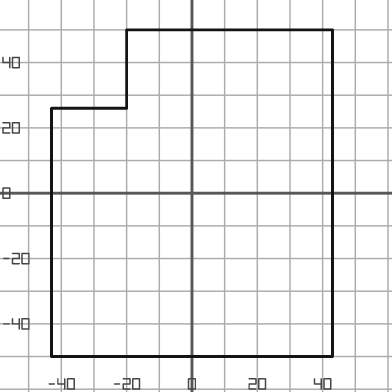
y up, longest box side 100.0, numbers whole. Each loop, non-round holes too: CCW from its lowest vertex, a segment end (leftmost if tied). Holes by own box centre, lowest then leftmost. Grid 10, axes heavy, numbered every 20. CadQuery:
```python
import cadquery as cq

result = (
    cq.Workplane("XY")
    .moveTo(-43.0, -50.0)
    .lineTo(43.0, -50.0)
    .lineTo(43.0, 50.0)
    .lineTo(-20.0, 50.0)
    .lineTo(-20.0, 26.0)
    .lineTo(-43.0, 26.0)
    .close()
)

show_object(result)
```